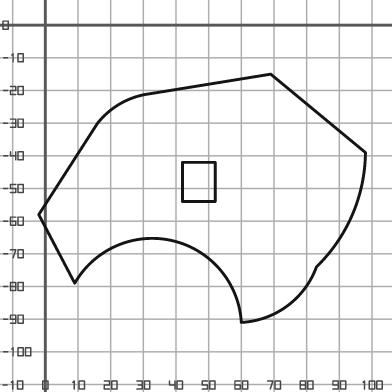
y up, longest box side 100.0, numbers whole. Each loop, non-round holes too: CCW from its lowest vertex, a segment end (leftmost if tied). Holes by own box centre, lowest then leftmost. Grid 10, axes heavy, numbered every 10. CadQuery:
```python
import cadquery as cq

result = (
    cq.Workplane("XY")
    .moveTo(60.0, -91.0)
    .threePointArc((74.0, -86.0), (83.0, -74.0))
    .threePointArc((94.0, -58.0), (98.0, -39.0))
    .lineTo(69.0, -15.0)
    .lineTo(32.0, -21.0)
    .threePointArc((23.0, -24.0), (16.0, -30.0))
    .lineTo(-2.0, -58.0)
    .lineTo(9.0, -79.0)
    .threePointArc((39.0, -66.0), (60.0, -91.0))
    .close()
    .moveTo(42.0, -54.0)
    .lineTo(52.0, -54.0)
    .lineTo(52.0, -42.0)
    .lineTo(42.0, -42.0)
    .close()
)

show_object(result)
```